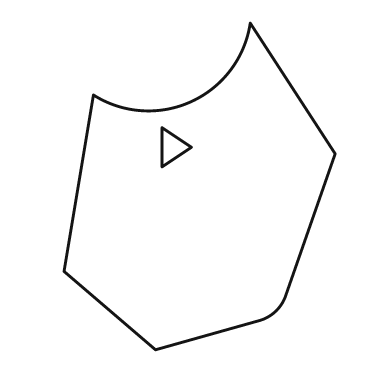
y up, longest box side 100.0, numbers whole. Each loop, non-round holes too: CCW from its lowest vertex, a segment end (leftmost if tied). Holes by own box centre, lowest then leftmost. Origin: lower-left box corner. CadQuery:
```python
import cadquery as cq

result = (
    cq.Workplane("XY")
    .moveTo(28.0, 0.0)
    .lineTo(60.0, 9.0)
    .threePointArc((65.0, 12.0), (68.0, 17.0))
    .lineTo(83.0, 60.0)
    .lineTo(57.0, 100.0)
    .threePointArc((39.0, 76.0), (9.0, 78.0))
    .lineTo(0.0, 24.0)
    .close()
    .moveTo(30.0, 56.0)
    .lineTo(39.0, 62.0)
    .lineTo(30.0, 68.0)
    .close()
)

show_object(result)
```